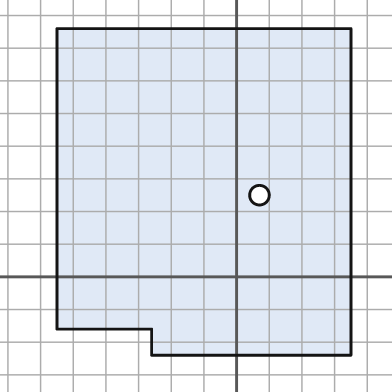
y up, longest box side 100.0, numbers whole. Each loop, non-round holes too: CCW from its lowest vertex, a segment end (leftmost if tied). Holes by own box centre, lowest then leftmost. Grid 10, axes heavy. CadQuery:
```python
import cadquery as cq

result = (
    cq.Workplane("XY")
    .moveTo(-26.0, -24.0)
    .lineTo(35.0, -24.0)
    .lineTo(35.0, 76.0)
    .lineTo(-55.0, 76.0)
    .lineTo(-55.0, -16.0)
    .lineTo(-26.0, -16.0)
    .close()
    .moveTo(7.0, 25.0)
    .circle(3.0)
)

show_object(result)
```